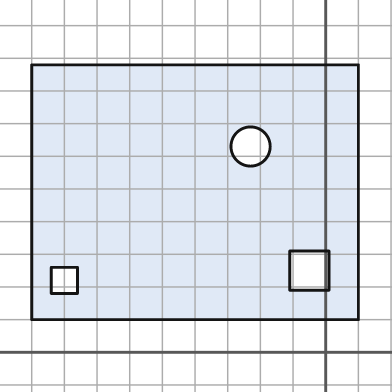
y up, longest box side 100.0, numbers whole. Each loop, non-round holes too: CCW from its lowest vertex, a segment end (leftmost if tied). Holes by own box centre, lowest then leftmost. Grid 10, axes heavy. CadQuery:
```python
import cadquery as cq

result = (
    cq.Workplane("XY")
    .moveTo(-90.0, 10.0)
    .lineTo(10.0, 10.0)
    .lineTo(10.0, 88.0)
    .lineTo(-90.0, 88.0)
    .close()
    .moveTo(-84.0, 18.0)
    .lineTo(-76.0, 18.0)
    .lineTo(-76.0, 26.0)
    .lineTo(-84.0, 26.0)
    .close()
    .moveTo(-11.0, 19.0)
    .lineTo(1.0, 19.0)
    .lineTo(1.0, 31.0)
    .lineTo(-11.0, 31.0)
    .close()
    .moveTo(-23.0, 63.0)
    .circle(6.0)
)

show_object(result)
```